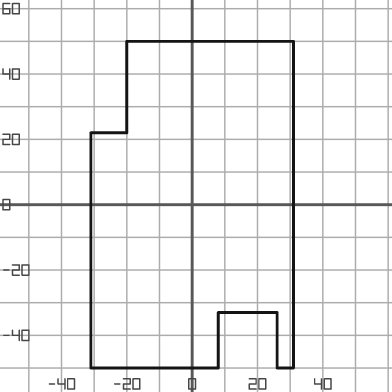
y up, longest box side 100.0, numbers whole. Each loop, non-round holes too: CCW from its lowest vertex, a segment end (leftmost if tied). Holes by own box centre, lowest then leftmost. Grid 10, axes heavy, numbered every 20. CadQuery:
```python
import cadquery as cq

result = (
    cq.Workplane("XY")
    .moveTo(-31.0, -50.0)
    .lineTo(8.0, -50.0)
    .lineTo(8.0, -33.0)
    .lineTo(26.0, -33.0)
    .lineTo(26.0, -50.0)
    .lineTo(31.0, -50.0)
    .lineTo(31.0, 50.0)
    .lineTo(-20.0, 50.0)
    .lineTo(-20.0, 22.0)
    .lineTo(-31.0, 22.0)
    .close()
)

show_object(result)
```